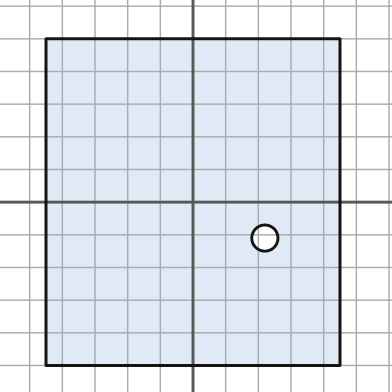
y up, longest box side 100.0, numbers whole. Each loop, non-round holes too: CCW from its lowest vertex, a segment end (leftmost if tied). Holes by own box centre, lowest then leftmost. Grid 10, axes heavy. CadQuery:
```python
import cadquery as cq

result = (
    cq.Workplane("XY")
    .moveTo(-45.0, -50.0)
    .lineTo(45.0, -50.0)
    .lineTo(45.0, 50.0)
    .lineTo(-45.0, 50.0)
    .close()
    .moveTo(22.0, -11.0)
    .circle(4.0)
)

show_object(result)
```